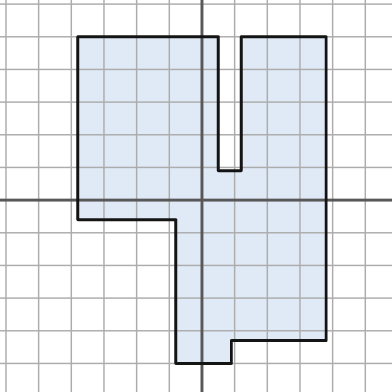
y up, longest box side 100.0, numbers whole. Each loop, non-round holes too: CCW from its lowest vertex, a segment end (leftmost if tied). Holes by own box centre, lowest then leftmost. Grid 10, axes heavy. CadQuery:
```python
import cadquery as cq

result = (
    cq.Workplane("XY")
    .moveTo(-8.0, -50.0)
    .lineTo(9.0, -50.0)
    .lineTo(9.0, -43.0)
    .lineTo(38.0, -43.0)
    .lineTo(38.0, 50.0)
    .lineTo(12.0, 50.0)
    .lineTo(12.0, 9.0)
    .lineTo(5.0, 9.0)
    .lineTo(5.0, 50.0)
    .lineTo(-38.0, 50.0)
    .lineTo(-38.0, -6.0)
    .lineTo(-8.0, -6.0)
    .close()
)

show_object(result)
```